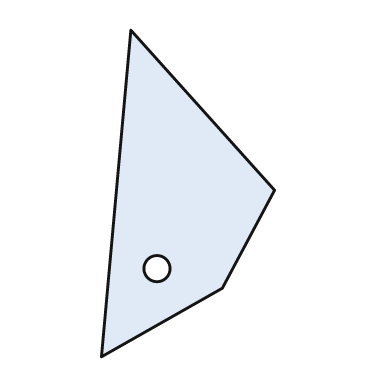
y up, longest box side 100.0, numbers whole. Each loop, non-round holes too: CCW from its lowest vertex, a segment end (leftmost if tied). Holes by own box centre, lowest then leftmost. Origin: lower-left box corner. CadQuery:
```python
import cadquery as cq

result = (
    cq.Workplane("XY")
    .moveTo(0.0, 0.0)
    .lineTo(37.0, 21.0)
    .lineTo(53.0, 51.0)
    .lineTo(9.0, 100.0)
    .close()
    .moveTo(17.0, 27.0)
    .circle(4.0)
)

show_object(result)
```